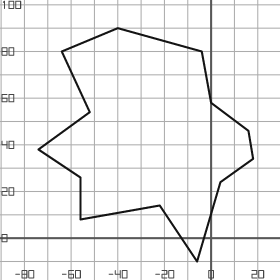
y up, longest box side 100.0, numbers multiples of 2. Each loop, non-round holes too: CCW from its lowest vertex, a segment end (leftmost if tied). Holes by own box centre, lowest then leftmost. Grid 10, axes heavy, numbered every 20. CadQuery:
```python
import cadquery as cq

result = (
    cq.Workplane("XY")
    .moveTo(-6.0, -10.0)
    .lineTo(4.0, 24.0)
    .lineTo(18.0, 34.0)
    .lineTo(16.0, 46.0)
    .lineTo(0.0, 58.0)
    .lineTo(-4.0, 80.0)
    .lineTo(-40.0, 90.0)
    .lineTo(-64.0, 80.0)
    .lineTo(-52.0, 54.0)
    .lineTo(-74.0, 38.0)
    .lineTo(-56.0, 26.0)
    .lineTo(-56.0, 8.0)
    .lineTo(-22.0, 14.0)
    .close()
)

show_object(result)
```